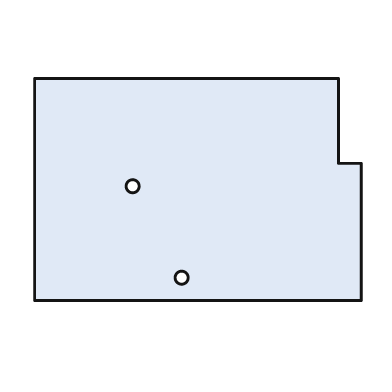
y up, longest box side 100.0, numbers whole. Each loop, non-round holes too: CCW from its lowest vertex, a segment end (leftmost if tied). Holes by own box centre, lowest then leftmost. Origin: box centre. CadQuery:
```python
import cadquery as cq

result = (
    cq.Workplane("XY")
    .moveTo(-50.0, -34.0)
    .lineTo(50.0, -34.0)
    .lineTo(50.0, 8.0)
    .lineTo(43.0, 8.0)
    .lineTo(43.0, 34.0)
    .lineTo(-50.0, 34.0)
    .close()
    .moveTo(-5.0, -27.0)
    .circle(2.0)
    .moveTo(-20.0, 1.0)
    .circle(2.0)
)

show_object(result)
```